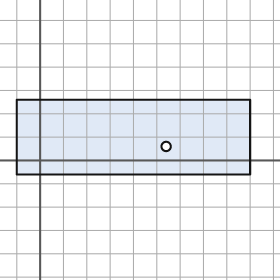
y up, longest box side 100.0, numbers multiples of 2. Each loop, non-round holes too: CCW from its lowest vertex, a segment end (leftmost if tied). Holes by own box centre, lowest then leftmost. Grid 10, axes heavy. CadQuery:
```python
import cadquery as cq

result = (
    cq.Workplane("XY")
    .moveTo(-10.0, -6.0)
    .lineTo(90.0, -6.0)
    .lineTo(90.0, 26.0)
    .lineTo(-10.0, 26.0)
    .close()
    .moveTo(54.0, 6.0)
    .circle(2.0)
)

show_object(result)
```